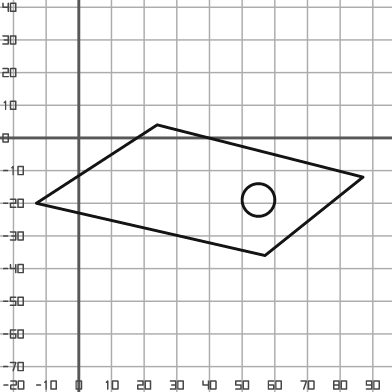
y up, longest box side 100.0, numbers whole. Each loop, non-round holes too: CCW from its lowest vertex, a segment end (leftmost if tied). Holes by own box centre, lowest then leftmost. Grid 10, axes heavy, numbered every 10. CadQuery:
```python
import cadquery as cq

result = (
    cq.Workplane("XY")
    .moveTo(57.0, -36.0)
    .lineTo(87.0, -12.0)
    .lineTo(24.0, 4.0)
    .lineTo(-13.0, -20.0)
    .close()
    .moveTo(55.0, -19.0)
    .circle(5.0)
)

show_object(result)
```